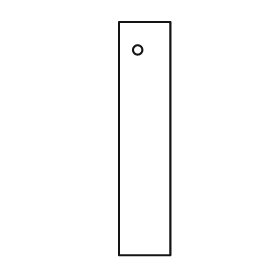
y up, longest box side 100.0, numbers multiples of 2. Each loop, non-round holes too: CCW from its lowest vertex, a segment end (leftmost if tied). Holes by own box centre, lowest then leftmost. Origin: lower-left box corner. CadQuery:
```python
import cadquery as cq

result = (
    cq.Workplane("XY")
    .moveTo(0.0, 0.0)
    .lineTo(22.0, 0.0)
    .lineTo(22.0, 100.0)
    .lineTo(0.0, 100.0)
    .close()
    .moveTo(8.0, 88.0)
    .circle(2.0)
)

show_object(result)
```